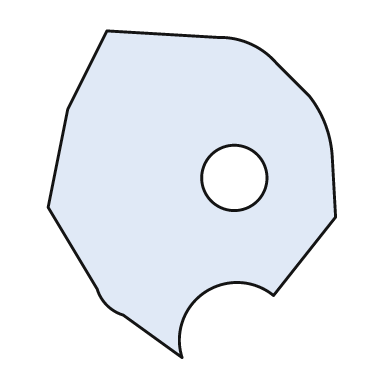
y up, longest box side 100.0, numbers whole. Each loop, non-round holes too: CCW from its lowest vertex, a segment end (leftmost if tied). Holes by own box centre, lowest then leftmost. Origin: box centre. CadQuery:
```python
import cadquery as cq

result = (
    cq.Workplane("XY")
    .moveTo(-3.0, -50.0)
    .threePointArc((4.0, -30.0), (25.0, -31.0))
    .lineTo(44.0, -7.0)
    .lineTo(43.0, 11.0)
    .threePointArc((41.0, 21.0), (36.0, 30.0))
    .lineTo(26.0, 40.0)
    .threePointArc((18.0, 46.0), (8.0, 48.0))
    .lineTo(-26.0, 50.0)
    .lineTo(-38.0, 26.0)
    .lineTo(-44.0, -4.0)
    .lineTo(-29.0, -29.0)
    .threePointArc((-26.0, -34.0), (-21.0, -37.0))
    .close()
    .moveTo(13.0, 5.0)
    .circle(10.0)
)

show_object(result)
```